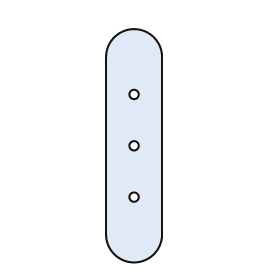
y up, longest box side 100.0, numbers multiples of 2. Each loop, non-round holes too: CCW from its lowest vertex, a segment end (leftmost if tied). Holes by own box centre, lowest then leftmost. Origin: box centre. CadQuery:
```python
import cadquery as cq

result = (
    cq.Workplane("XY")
    .moveTo(-12.0, -38.0)
    .threePointArc((0.0, -50.0), (12.0, -38.0))
    .lineTo(12.0, 38.0)
    .threePointArc((0.0, 50.0), (-12.0, 38.0))
    .close()
    .moveTo(0.0, -22.0)
    .circle(2.0)
    .moveTo(0.0, 0.0)
    .circle(2.0)
    .moveTo(0.0, 22.0)
    .circle(2.0)
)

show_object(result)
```